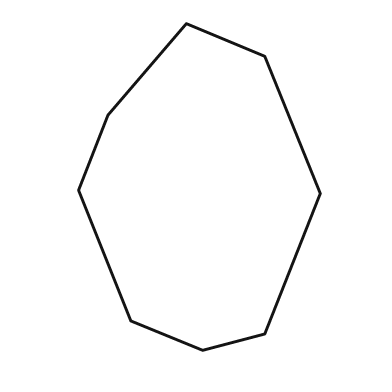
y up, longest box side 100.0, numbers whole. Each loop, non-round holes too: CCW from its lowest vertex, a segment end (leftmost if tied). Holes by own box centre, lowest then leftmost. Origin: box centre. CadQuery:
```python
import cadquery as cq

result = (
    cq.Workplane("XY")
    .moveTo(1.0, -50.0)
    .lineTo(20.0, -45.0)
    .lineTo(37.0, -2.0)
    .lineTo(20.0, 40.0)
    .lineTo(-4.0, 50.0)
    .lineTo(-28.0, 22.0)
    .lineTo(-37.0, -1.0)
    .lineTo(-21.0, -41.0)
    .close()
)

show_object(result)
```